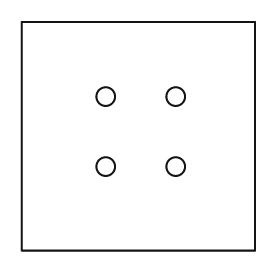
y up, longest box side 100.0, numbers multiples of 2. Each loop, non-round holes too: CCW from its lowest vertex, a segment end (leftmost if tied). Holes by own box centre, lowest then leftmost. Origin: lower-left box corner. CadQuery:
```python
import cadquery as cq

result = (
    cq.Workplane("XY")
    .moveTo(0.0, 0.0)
    .lineTo(100.0, 0.0)
    .lineTo(100.0, 98.0)
    .lineTo(0.0, 98.0)
    .close()
    .moveTo(36.0, 36.0)
    .circle(4.0)
    .moveTo(66.0, 36.0)
    .circle(4.0)
    .moveTo(36.0, 66.0)
    .circle(4.0)
    .moveTo(66.0, 66.0)
    .circle(4.0)
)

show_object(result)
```